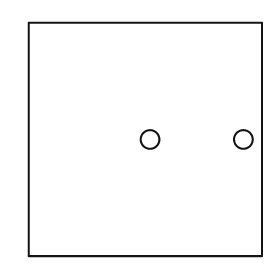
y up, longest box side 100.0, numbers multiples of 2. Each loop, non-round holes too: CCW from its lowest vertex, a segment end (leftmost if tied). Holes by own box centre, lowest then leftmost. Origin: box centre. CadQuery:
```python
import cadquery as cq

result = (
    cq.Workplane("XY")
    .moveTo(-50.0, -50.0)
    .lineTo(50.0, -50.0)
    .lineTo(50.0, 50.0)
    .lineTo(-50.0, 50.0)
    .close()
    .moveTo(2.0, 0.0)
    .circle(4.0)
    .moveTo(42.0, 0.0)
    .circle(4.0)
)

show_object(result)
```